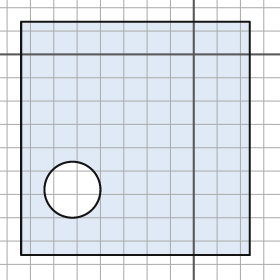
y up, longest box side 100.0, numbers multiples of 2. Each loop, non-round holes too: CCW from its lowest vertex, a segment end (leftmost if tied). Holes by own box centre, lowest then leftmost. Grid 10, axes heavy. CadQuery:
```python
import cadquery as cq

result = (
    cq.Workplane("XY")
    .moveTo(-74.0, -86.0)
    .lineTo(24.0, -86.0)
    .lineTo(24.0, 14.0)
    .lineTo(-74.0, 14.0)
    .close()
    .moveTo(-52.0, -58.0)
    .circle(12.0)
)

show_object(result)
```